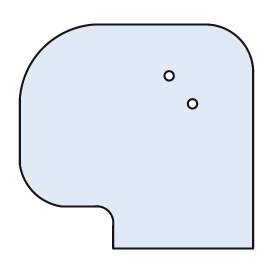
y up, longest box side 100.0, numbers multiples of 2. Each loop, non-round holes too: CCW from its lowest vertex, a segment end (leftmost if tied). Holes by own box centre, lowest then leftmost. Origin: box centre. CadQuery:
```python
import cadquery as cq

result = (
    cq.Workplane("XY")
    .moveTo(-10.0, -48.0)
    .lineTo(50.0, -48.0)
    .lineTo(50.0, 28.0)
    .threePointArc((44.0, 42.0), (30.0, 48.0))
    .lineTo(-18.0, 48.0)
    .threePointArc((-40.0, 38.0), (-50.0, 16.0))
    .lineTo(-50.0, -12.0)
    .threePointArc((-44.0, -24.0), (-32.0, -30.0))
    .lineTo(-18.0, -30.0)
    .threePointArc((-12.0, -32.0), (-10.0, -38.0))
    .close()
    .moveTo(24.0, 14.0)
    .circle(2.0)
    .moveTo(14.0, 26.0)
    .circle(2.0)
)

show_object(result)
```